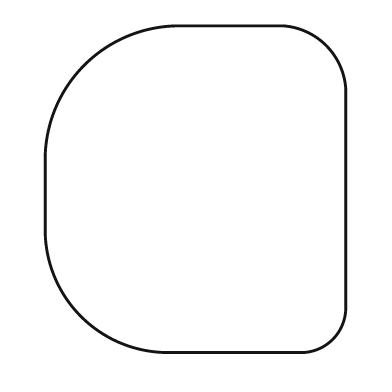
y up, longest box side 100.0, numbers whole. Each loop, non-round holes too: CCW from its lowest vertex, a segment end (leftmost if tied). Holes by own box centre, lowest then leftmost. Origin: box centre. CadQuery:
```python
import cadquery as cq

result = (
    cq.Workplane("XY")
    .moveTo(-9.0, -50.0)
    .lineTo(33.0, -50.0)
    .threePointArc((42.0, -46.0), (46.0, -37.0))
    .lineTo(46.0, 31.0)
    .threePointArc((40.0, 44.0), (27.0, 50.0))
    .lineTo(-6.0, 50.0)
    .threePointArc((-34.0, 38.0), (-46.0, 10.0))
    .lineTo(-46.0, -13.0)
    .threePointArc((-35.0, -39.0), (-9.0, -50.0))
    .close()
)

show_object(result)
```